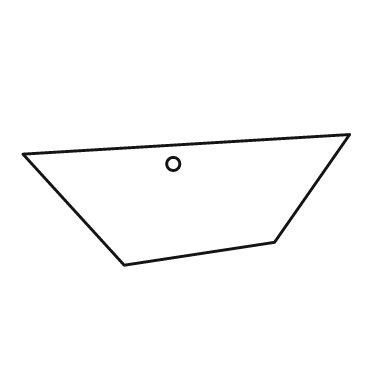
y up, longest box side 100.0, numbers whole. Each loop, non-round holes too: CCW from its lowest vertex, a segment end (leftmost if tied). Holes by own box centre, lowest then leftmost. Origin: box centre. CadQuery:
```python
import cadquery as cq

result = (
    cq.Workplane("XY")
    .moveTo(-19.0, -20.0)
    .lineTo(27.0, -13.0)
    .lineTo(50.0, 20.0)
    .lineTo(-50.0, 14.0)
    .close()
    .moveTo(-4.0, 11.0)
    .circle(2.0)
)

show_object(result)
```